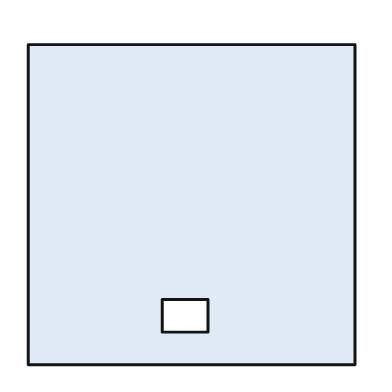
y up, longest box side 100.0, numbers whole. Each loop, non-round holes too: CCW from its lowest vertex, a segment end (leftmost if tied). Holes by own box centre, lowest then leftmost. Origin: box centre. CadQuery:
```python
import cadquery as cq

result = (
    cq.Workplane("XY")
    .moveTo(-50.0, -49.0)
    .lineTo(50.0, -49.0)
    .lineTo(50.0, 49.0)
    .lineTo(-50.0, 49.0)
    .close()
    .moveTo(-9.0, -39.0)
    .lineTo(5.0, -39.0)
    .lineTo(5.0, -29.0)
    .lineTo(-9.0, -29.0)
    .close()
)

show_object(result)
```